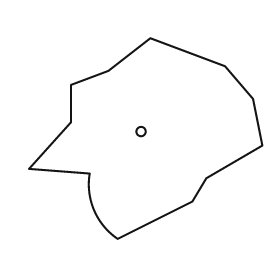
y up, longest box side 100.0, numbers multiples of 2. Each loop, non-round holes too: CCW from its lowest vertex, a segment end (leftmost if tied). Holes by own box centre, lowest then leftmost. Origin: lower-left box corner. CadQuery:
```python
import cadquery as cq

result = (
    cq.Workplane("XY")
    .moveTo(38.0, 0.0)
    .lineTo(70.0, 16.0)
    .lineTo(76.0, 26.0)
    .lineTo(100.0, 40.0)
    .lineTo(96.0, 60.0)
    .lineTo(84.0, 74.0)
    .lineTo(52.0, 86.0)
    .lineTo(34.0, 72.0)
    .lineTo(18.0, 66.0)
    .lineTo(18.0, 50.0)
    .lineTo(0.0, 30.0)
    .lineTo(26.0, 28.0)
    .threePointArc((28.0, 12.0), (38.0, 0.0))
    .close()
    .moveTo(48.0, 46.0)
    .circle(2.0)
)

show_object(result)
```